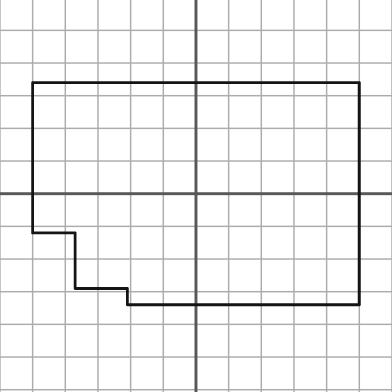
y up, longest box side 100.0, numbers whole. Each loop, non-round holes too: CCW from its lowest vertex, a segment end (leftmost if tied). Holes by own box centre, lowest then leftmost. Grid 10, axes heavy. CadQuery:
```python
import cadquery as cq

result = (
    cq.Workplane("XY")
    .moveTo(-21.0, -34.0)
    .lineTo(50.0, -34.0)
    .lineTo(50.0, 34.0)
    .lineTo(-50.0, 34.0)
    .lineTo(-50.0, -12.0)
    .lineTo(-37.0, -12.0)
    .lineTo(-37.0, -29.0)
    .lineTo(-21.0, -29.0)
    .close()
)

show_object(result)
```